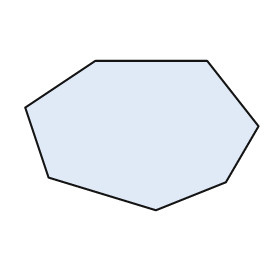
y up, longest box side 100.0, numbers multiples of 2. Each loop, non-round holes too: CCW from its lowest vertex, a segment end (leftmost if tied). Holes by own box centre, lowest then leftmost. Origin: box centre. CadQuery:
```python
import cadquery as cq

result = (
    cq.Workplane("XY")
    .moveTo(6.0, -32.0)
    .lineTo(36.0, -20.0)
    .lineTo(50.0, 4.0)
    .lineTo(28.0, 32.0)
    .lineTo(-20.0, 32.0)
    .lineTo(-50.0, 12.0)
    .lineTo(-40.0, -18.0)
    .close()
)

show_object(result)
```